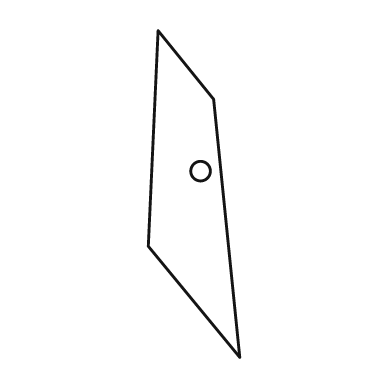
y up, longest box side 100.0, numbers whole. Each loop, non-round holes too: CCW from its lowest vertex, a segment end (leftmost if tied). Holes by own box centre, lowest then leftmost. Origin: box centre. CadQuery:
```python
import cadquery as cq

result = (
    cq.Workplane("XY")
    .moveTo(14.0, -50.0)
    .lineTo(6.0, 29.0)
    .lineTo(-11.0, 50.0)
    .lineTo(-14.0, -16.0)
    .close()
    .moveTo(2.0, 7.0)
    .circle(3.0)
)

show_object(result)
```